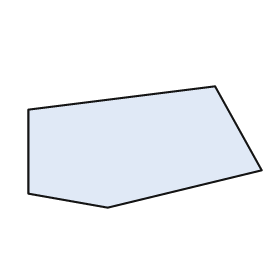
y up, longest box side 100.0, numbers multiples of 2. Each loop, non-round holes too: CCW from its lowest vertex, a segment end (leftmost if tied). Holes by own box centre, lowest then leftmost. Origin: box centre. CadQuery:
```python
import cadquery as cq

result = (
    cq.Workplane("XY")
    .moveTo(-16.0, -26.0)
    .lineTo(50.0, -10.0)
    .lineTo(30.0, 26.0)
    .lineTo(-50.0, 16.0)
    .lineTo(-50.0, -20.0)
    .close()
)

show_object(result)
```